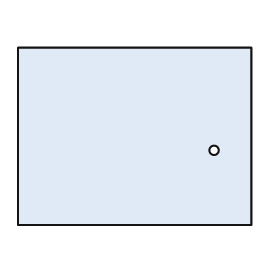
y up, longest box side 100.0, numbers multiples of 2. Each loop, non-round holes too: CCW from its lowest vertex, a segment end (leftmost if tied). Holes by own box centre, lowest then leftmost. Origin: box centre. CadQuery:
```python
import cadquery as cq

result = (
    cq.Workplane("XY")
    .moveTo(-50.0, -38.0)
    .lineTo(50.0, -38.0)
    .lineTo(50.0, 38.0)
    .lineTo(-50.0, 38.0)
    .close()
    .moveTo(34.0, -6.0)
    .circle(2.0)
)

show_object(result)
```